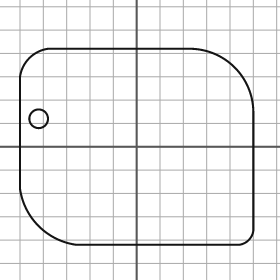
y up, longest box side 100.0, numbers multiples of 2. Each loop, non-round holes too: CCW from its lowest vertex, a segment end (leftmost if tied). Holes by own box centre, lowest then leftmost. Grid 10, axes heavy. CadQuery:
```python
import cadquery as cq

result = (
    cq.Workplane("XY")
    .moveTo(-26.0, -42.0)
    .lineTo(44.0, -42.0)
    .threePointArc((48.0, -40.0), (50.0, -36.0))
    .lineTo(50.0, 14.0)
    .threePointArc((42.0, 34.0), (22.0, 42.0))
    .lineTo(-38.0, 42.0)
    .threePointArc((-46.0, 38.0), (-50.0, 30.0))
    .lineTo(-50.0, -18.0)
    .threePointArc((-42.0, -34.0), (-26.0, -42.0))
    .close()
    .moveTo(-42.0, 12.0)
    .circle(4.0)
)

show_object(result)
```